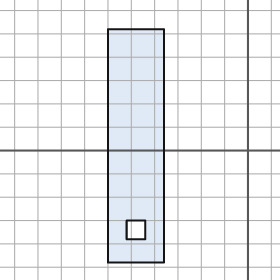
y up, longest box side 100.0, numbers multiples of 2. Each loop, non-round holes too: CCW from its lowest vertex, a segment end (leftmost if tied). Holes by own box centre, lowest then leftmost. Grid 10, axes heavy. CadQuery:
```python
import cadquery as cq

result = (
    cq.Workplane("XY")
    .moveTo(-60.0, -48.0)
    .lineTo(-36.0, -48.0)
    .lineTo(-36.0, 52.0)
    .lineTo(-60.0, 52.0)
    .close()
    .moveTo(-52.0, -38.0)
    .lineTo(-44.0, -38.0)
    .lineTo(-44.0, -30.0)
    .lineTo(-52.0, -30.0)
    .close()
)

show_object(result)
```